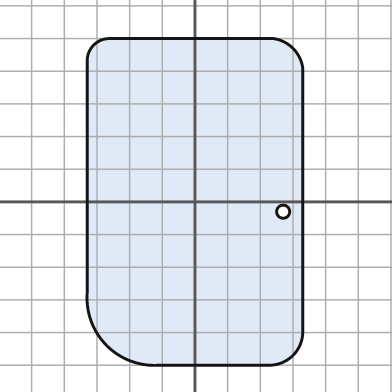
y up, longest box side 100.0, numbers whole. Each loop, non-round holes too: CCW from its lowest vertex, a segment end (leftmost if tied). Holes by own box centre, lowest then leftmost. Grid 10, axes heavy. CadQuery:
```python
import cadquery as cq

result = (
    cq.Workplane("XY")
    .moveTo(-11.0, -50.0)
    .lineTo(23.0, -50.0)
    .threePointArc((30.0, -47.0), (33.0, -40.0))
    .lineTo(33.0, 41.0)
    .threePointArc((30.0, 47.0), (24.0, 50.0))
    .lineTo(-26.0, 50.0)
    .threePointArc((-31.0, 48.0), (-33.0, 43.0))
    .lineTo(-33.0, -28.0)
    .threePointArc((-27.0, -44.0), (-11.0, -50.0))
    .close()
    .moveTo(27.0, -3.0)
    .circle(2.0)
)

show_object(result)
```